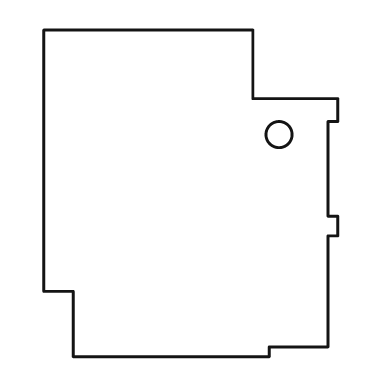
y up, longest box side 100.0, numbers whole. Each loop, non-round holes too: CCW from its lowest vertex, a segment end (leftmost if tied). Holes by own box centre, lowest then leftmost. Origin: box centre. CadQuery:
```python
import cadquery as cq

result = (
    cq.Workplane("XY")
    .moveTo(-36.0, -50.0)
    .lineTo(24.0, -50.0)
    .lineTo(24.0, -47.0)
    .lineTo(42.0, -47.0)
    .lineTo(42.0, -13.0)
    .lineTo(45.0, -13.0)
    .lineTo(45.0, -7.0)
    .lineTo(42.0, -7.0)
    .lineTo(42.0, 22.0)
    .lineTo(45.0, 22.0)
    .lineTo(45.0, 29.0)
    .lineTo(19.0, 29.0)
    .lineTo(19.0, 50.0)
    .lineTo(-45.0, 50.0)
    .lineTo(-45.0, -30.0)
    .lineTo(-36.0, -30.0)
    .close()
    .moveTo(27.0, 18.0)
    .circle(4.0)
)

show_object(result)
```